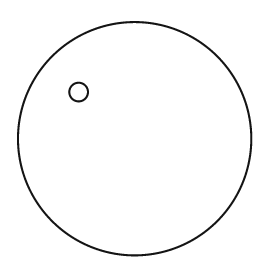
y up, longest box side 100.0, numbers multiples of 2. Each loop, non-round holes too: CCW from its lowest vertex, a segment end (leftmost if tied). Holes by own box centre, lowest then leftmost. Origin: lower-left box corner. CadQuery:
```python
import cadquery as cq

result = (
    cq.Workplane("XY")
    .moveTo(50.0, 50.0)
    .circle(50.0)
    .moveTo(26.0, 70.0)
    .circle(4.0)
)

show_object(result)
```